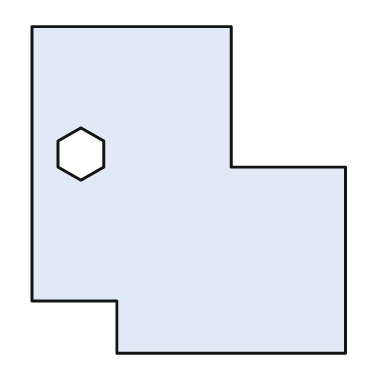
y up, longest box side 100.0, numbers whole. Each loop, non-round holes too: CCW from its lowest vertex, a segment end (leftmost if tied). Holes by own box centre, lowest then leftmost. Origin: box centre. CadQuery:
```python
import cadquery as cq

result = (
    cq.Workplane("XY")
    .moveTo(-22.0, -50.0)
    .lineTo(48.0, -50.0)
    .lineTo(48.0, 7.0)
    .lineTo(13.0, 7.0)
    .lineTo(13.0, 50.0)
    .lineTo(-48.0, 50.0)
    .lineTo(-48.0, -34.0)
    .lineTo(-22.0, -34.0)
    .close()
    .moveTo(-33.0, 3.0)
    .lineTo(-26.0, 7.0)
    .lineTo(-26.0, 15.0)
    .lineTo(-33.0, 19.0)
    .lineTo(-40.0, 15.0)
    .lineTo(-40.0, 7.0)
    .close()
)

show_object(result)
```